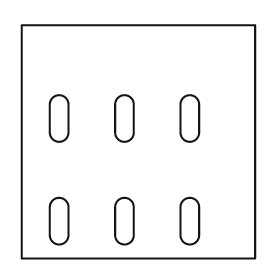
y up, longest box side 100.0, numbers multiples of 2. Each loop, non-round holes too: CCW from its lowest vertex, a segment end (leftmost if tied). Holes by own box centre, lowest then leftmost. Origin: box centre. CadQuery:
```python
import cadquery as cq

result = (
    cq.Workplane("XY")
    .moveTo(-50.0, -50.0)
    .lineTo(50.0, -50.0)
    .lineTo(50.0, 50.0)
    .lineTo(-50.0, 50.0)
    .close()
    .moveTo(-38.0, -40.0)
    .threePointArc((-34.0, -44.0), (-30.0, -40.0))
    .lineTo(-30.0, -28.0)
    .threePointArc((-34.0, -24.0), (-38.0, -28.0))
    .close()
    .moveTo(-10.0, -40.0)
    .threePointArc((-6.0, -44.0), (-2.0, -40.0))
    .lineTo(-2.0, -28.0)
    .threePointArc((-6.0, -24.0), (-10.0, -28.0))
    .close()
    .moveTo(18.0, -40.0)
    .threePointArc((22.0, -44.0), (26.0, -40.0))
    .lineTo(26.0, -28.0)
    .threePointArc((22.0, -24.0), (18.0, -28.0))
    .close()
    .moveTo(-38.0, 4.0)
    .threePointArc((-34.0, 0.0), (-30.0, 4.0))
    .lineTo(-30.0, 16.0)
    .threePointArc((-34.0, 20.0), (-38.0, 16.0))
    .close()
    .moveTo(-10.0, 4.0)
    .threePointArc((-6.0, 0.0), (-2.0, 4.0))
    .lineTo(-2.0, 16.0)
    .threePointArc((-6.0, 20.0), (-10.0, 16.0))
    .close()
    .moveTo(18.0, 4.0)
    .threePointArc((22.0, 0.0), (26.0, 4.0))
    .lineTo(26.0, 16.0)
    .threePointArc((22.0, 20.0), (18.0, 16.0))
    .close()
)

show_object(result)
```